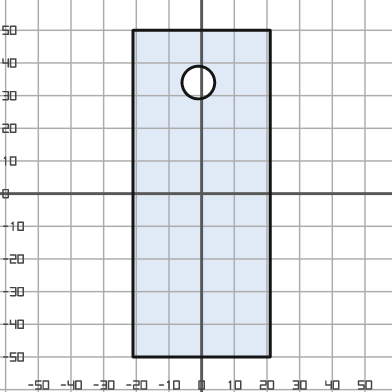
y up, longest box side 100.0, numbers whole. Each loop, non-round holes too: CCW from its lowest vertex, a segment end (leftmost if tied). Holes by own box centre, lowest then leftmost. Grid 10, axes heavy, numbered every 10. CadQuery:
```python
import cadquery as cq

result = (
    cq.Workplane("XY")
    .moveTo(-21.0, -50.0)
    .lineTo(21.0, -50.0)
    .lineTo(21.0, 50.0)
    .lineTo(-21.0, 50.0)
    .close()
    .moveTo(-1.0, 34.0)
    .circle(5.0)
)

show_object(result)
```